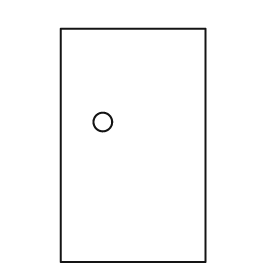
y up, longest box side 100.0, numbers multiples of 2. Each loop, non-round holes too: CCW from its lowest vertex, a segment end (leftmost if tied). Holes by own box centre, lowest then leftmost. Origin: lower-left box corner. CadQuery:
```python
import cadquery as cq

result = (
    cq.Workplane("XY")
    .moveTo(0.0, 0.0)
    .lineTo(62.0, 0.0)
    .lineTo(62.0, 100.0)
    .lineTo(0.0, 100.0)
    .close()
    .moveTo(18.0, 60.0)
    .circle(4.0)
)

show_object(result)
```